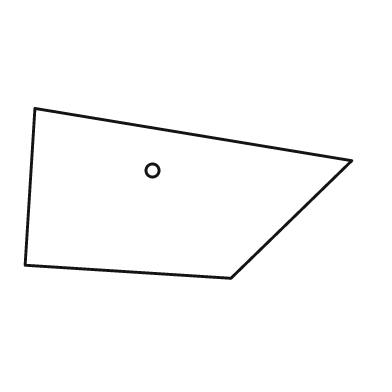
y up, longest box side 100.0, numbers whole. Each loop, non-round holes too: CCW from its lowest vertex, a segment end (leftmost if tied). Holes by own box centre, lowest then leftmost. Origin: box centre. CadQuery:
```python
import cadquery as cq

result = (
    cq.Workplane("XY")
    .moveTo(13.0, -26.0)
    .lineTo(50.0, 10.0)
    .lineTo(-47.0, 26.0)
    .lineTo(-50.0, -22.0)
    .close()
    .moveTo(-11.0, 7.0)
    .circle(2.0)
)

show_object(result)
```